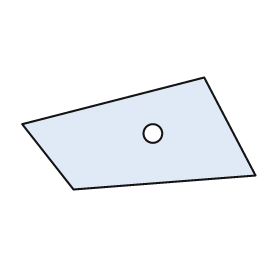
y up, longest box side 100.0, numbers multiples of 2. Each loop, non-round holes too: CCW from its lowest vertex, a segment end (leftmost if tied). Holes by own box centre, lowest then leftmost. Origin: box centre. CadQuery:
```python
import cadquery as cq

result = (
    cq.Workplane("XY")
    .moveTo(-28.0, -24.0)
    .lineTo(50.0, -18.0)
    .lineTo(28.0, 24.0)
    .lineTo(-50.0, 4.0)
    .close()
    .moveTo(6.0, 0.0)
    .circle(4.0)
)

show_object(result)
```